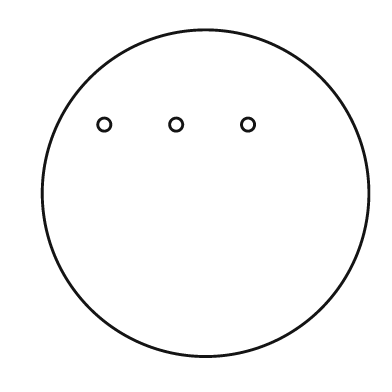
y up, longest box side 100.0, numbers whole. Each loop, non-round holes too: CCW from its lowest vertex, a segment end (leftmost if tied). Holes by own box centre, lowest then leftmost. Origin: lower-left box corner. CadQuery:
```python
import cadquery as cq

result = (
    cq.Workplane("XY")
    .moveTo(50.0, 50.0)
    .circle(50.0)
    .moveTo(19.0, 71.0)
    .circle(2.0)
    .moveTo(41.0, 71.0)
    .circle(2.0)
    .moveTo(63.0, 71.0)
    .circle(2.0)
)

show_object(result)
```